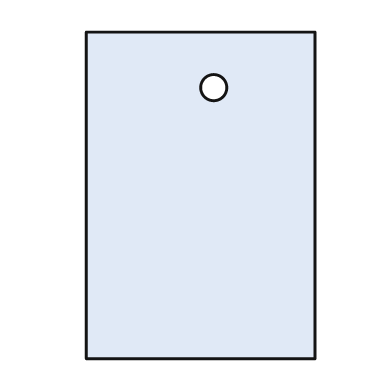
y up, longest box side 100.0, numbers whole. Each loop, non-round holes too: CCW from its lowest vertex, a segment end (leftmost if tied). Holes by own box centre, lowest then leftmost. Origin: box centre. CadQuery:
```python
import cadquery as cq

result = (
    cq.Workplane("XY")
    .moveTo(-35.0, -50.0)
    .lineTo(35.0, -50.0)
    .lineTo(35.0, 50.0)
    .lineTo(-35.0, 50.0)
    .close()
    .moveTo(4.0, 33.0)
    .circle(4.0)
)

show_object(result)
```